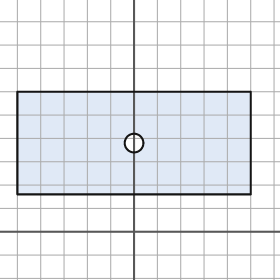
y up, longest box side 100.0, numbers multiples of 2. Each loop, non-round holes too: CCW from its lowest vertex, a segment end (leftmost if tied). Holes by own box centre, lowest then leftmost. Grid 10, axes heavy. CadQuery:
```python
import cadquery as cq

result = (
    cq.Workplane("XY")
    .moveTo(-50.0, 16.0)
    .lineTo(50.0, 16.0)
    .lineTo(50.0, 60.0)
    .lineTo(-50.0, 60.0)
    .close()
    .moveTo(0.0, 38.0)
    .circle(4.0)
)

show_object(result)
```